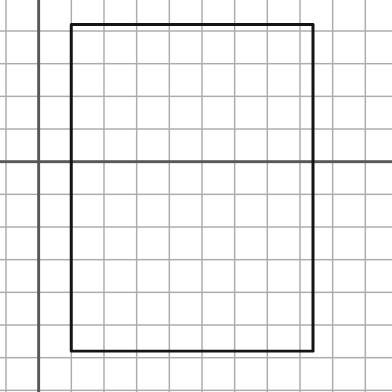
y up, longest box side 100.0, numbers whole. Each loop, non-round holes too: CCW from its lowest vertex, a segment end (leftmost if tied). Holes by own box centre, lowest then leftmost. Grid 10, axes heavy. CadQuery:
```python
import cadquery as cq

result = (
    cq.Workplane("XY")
    .moveTo(10.0, -58.0)
    .lineTo(84.0, -58.0)
    .lineTo(84.0, 42.0)
    .lineTo(10.0, 42.0)
    .close()
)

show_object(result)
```